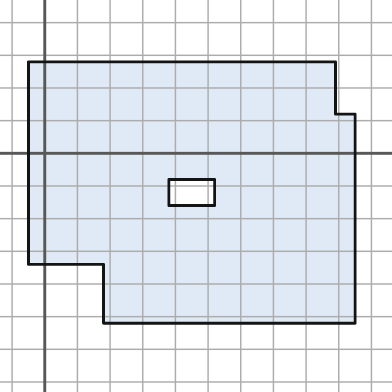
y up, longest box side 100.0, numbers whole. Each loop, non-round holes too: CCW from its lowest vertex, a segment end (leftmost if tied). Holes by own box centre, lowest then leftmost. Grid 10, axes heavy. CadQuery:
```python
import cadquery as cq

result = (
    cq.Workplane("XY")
    .moveTo(18.0, -52.0)
    .lineTo(95.0, -52.0)
    .lineTo(95.0, 12.0)
    .lineTo(89.0, 12.0)
    .lineTo(89.0, 28.0)
    .lineTo(-5.0, 28.0)
    .lineTo(-5.0, -34.0)
    .lineTo(18.0, -34.0)
    .close()
    .moveTo(38.0, -16.0)
    .lineTo(52.0, -16.0)
    .lineTo(52.0, -8.0)
    .lineTo(38.0, -8.0)
    .close()
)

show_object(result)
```